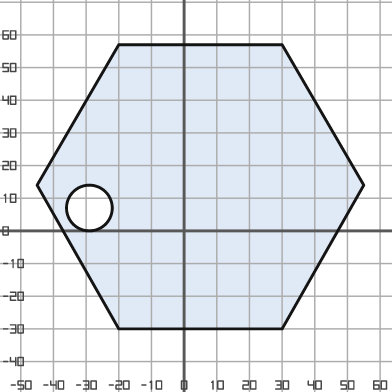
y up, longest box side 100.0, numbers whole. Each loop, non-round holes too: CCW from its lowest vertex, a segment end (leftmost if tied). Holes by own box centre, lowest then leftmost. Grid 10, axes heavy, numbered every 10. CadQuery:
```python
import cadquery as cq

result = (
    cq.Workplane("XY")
    .moveTo(-20.0, -30.0)
    .lineTo(30.0, -30.0)
    .lineTo(55.0, 14.0)
    .lineTo(30.0, 57.0)
    .lineTo(-20.0, 57.0)
    .lineTo(-45.0, 14.0)
    .close()
    .moveTo(-29.0, 7.0)
    .circle(7.0)
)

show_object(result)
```